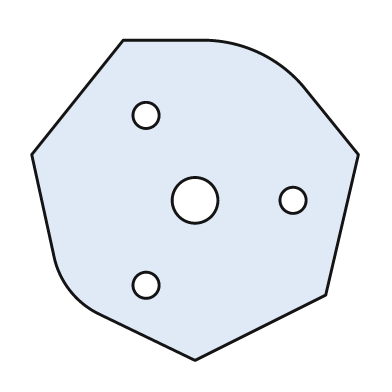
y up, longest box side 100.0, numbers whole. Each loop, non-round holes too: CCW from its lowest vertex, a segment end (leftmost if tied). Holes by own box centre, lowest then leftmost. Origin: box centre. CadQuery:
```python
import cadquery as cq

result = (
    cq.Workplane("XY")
    .moveTo(0.0, -49.0)
    .lineTo(40.0, -29.0)
    .lineTo(50.0, 14.0)
    .lineTo(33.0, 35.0)
    .threePointArc((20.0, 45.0), (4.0, 49.0))
    .lineTo(-22.0, 49.0)
    .lineTo(-50.0, 14.0)
    .lineTo(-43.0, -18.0)
    .threePointArc((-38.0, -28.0), (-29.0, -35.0))
    .close()
    .moveTo(-15.0, -26.0)
    .circle(4.0)
    .moveTo(0.0, 0.0)
    .circle(7.0)
    .moveTo(30.0, 0.0)
    .circle(4.0)
    .moveTo(-15.0, 26.0)
    .circle(4.0)
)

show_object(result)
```